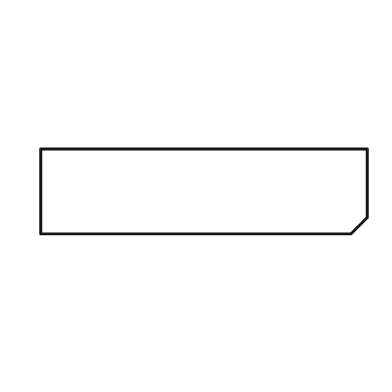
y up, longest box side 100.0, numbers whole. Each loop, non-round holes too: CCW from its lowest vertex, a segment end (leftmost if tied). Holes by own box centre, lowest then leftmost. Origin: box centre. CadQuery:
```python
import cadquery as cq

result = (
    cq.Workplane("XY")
    .moveTo(-50.0, -13.0)
    .lineTo(45.0, -13.0)
    .lineTo(50.0, -8.0)
    .lineTo(50.0, 13.0)
    .lineTo(-50.0, 13.0)
    .close()
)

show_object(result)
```